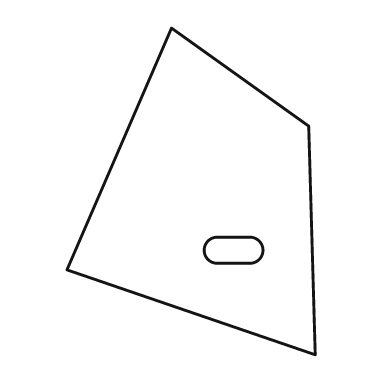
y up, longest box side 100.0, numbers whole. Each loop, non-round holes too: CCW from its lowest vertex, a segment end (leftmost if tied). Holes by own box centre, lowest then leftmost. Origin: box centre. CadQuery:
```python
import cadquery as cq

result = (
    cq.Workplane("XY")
    .moveTo(38.0, -50.0)
    .lineTo(36.0, 20.0)
    .lineTo(-6.0, 50.0)
    .lineTo(-38.0, -24.0)
    .close()
    .moveTo(8.0, -22.0)
    .lineTo(18.0, -22.0)
    .threePointArc((22.0, -18.0), (18.0, -14.0))
    .lineTo(8.0, -14.0)
    .threePointArc((4.0, -18.0), (8.0, -22.0))
    .close()
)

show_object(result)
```